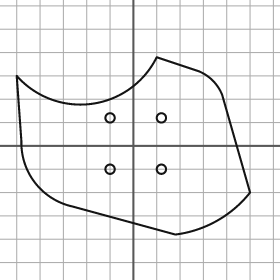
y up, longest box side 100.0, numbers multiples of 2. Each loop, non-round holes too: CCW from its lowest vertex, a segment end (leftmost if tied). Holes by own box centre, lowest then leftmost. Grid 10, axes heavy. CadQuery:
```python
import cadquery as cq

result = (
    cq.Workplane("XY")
    .moveTo(18.0, -38.0)
    .threePointArc((36.0, -32.0), (50.0, -20.0))
    .lineTo(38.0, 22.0)
    .threePointArc((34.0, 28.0), (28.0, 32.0))
    .lineTo(10.0, 38.0)
    .threePointArc((-18.0, 18.0), (-50.0, 30.0))
    .lineTo(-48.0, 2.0)
    .threePointArc((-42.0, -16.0), (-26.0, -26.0))
    .close()
    .moveTo(-10.0, -10.0)
    .circle(2.0)
    .moveTo(12.0, -10.0)
    .circle(2.0)
    .moveTo(-10.0, 12.0)
    .circle(2.0)
    .moveTo(12.0, 12.0)
    .circle(2.0)
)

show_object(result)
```